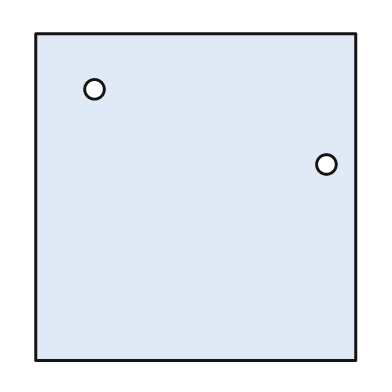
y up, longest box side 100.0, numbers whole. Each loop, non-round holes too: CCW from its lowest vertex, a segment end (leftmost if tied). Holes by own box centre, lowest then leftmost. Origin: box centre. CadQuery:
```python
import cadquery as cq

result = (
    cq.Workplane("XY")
    .moveTo(-49.0, -50.0)
    .lineTo(49.0, -50.0)
    .lineTo(49.0, 50.0)
    .lineTo(-49.0, 50.0)
    .close()
    .moveTo(40.0, 10.0)
    .circle(3.0)
    .moveTo(-31.0, 33.0)
    .circle(3.0)
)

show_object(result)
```